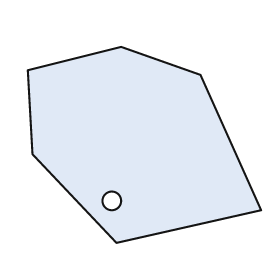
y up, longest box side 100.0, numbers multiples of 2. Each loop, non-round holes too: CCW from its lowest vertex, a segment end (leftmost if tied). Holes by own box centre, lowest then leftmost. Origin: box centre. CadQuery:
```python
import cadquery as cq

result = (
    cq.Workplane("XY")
    .moveTo(-12.0, -42.0)
    .lineTo(50.0, -28.0)
    .lineTo(24.0, 30.0)
    .lineTo(-10.0, 42.0)
    .lineTo(-50.0, 32.0)
    .lineTo(-48.0, -4.0)
    .close()
    .moveTo(-14.0, -24.0)
    .circle(4.0)
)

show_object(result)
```